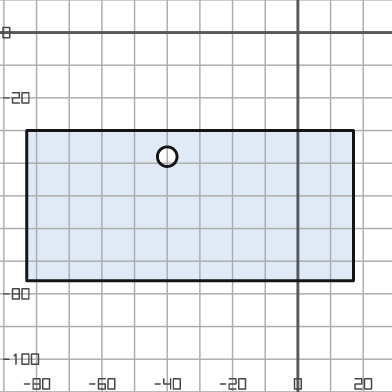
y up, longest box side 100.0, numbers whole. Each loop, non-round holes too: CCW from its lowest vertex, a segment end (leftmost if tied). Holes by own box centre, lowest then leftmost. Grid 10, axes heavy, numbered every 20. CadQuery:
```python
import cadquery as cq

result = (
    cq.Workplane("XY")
    .moveTo(-83.0, -76.0)
    .lineTo(17.0, -76.0)
    .lineTo(17.0, -30.0)
    .lineTo(-83.0, -30.0)
    .close()
    .moveTo(-40.0, -38.0)
    .circle(3.0)
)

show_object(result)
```